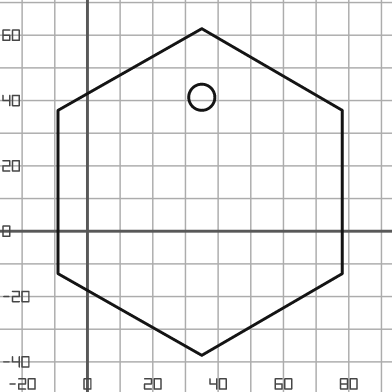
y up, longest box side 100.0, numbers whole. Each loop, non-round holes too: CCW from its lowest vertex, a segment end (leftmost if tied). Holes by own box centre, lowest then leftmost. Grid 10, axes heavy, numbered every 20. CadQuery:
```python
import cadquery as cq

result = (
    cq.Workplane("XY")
    .moveTo(35.0, -38.0)
    .lineTo(78.0, -13.0)
    .lineTo(78.0, 37.0)
    .lineTo(35.0, 62.0)
    .lineTo(-9.0, 37.0)
    .lineTo(-9.0, -13.0)
    .close()
    .moveTo(35.0, 41.0)
    .circle(4.0)
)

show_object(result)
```